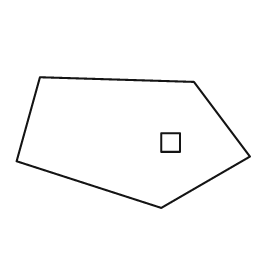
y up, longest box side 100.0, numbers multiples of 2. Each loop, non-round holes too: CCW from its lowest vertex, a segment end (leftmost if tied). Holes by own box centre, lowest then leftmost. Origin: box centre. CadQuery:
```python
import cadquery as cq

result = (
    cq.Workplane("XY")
    .moveTo(12.0, -28.0)
    .lineTo(50.0, -6.0)
    .lineTo(26.0, 26.0)
    .lineTo(-40.0, 28.0)
    .lineTo(-50.0, -8.0)
    .close()
    .moveTo(12.0, -4.0)
    .lineTo(20.0, -4.0)
    .lineTo(20.0, 4.0)
    .lineTo(12.0, 4.0)
    .close()
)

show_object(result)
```